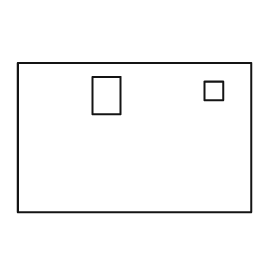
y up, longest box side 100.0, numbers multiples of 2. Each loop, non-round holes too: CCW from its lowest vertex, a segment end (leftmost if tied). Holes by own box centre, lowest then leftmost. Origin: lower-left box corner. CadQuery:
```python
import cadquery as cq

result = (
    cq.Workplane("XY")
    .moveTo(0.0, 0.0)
    .lineTo(100.0, 0.0)
    .lineTo(100.0, 64.0)
    .lineTo(0.0, 64.0)
    .close()
    .moveTo(32.0, 42.0)
    .lineTo(44.0, 42.0)
    .lineTo(44.0, 58.0)
    .lineTo(32.0, 58.0)
    .close()
    .moveTo(80.0, 48.0)
    .lineTo(88.0, 48.0)
    .lineTo(88.0, 56.0)
    .lineTo(80.0, 56.0)
    .close()
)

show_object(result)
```